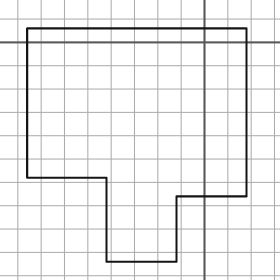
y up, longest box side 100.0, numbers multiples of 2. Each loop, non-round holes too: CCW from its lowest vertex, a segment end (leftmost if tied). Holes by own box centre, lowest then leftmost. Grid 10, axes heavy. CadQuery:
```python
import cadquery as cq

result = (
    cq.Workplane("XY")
    .moveTo(-42.0, -94.0)
    .lineTo(-12.0, -94.0)
    .lineTo(-12.0, -66.0)
    .lineTo(18.0, -66.0)
    .lineTo(18.0, 6.0)
    .lineTo(-76.0, 6.0)
    .lineTo(-76.0, -58.0)
    .lineTo(-42.0, -58.0)
    .close()
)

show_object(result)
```